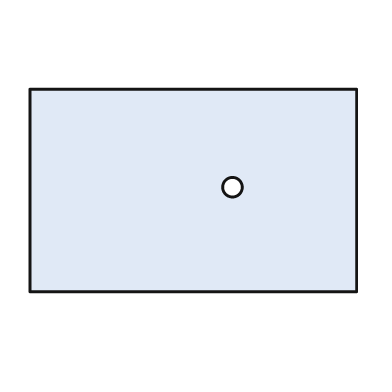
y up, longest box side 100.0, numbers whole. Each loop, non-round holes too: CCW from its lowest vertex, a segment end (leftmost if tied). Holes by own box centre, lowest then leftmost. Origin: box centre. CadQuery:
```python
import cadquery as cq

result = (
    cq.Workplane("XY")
    .moveTo(-50.0, -31.0)
    .lineTo(50.0, -31.0)
    .lineTo(50.0, 31.0)
    .lineTo(-50.0, 31.0)
    .close()
    .moveTo(12.0, 1.0)
    .circle(3.0)
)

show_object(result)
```